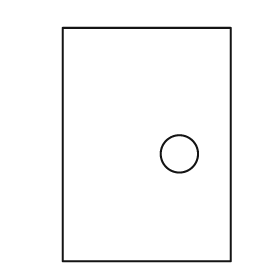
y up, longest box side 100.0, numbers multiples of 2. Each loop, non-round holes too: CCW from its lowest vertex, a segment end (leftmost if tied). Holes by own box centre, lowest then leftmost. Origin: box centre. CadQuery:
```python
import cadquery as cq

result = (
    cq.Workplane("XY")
    .moveTo(-36.0, -50.0)
    .lineTo(36.0, -50.0)
    .lineTo(36.0, 50.0)
    .lineTo(-36.0, 50.0)
    .close()
    .moveTo(14.0, -4.0)
    .circle(8.0)
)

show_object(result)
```